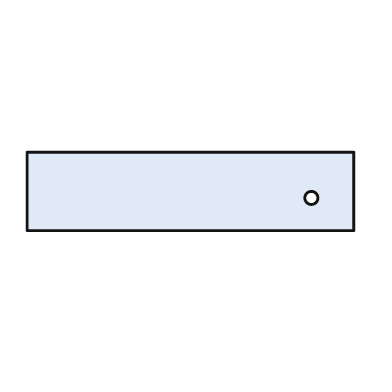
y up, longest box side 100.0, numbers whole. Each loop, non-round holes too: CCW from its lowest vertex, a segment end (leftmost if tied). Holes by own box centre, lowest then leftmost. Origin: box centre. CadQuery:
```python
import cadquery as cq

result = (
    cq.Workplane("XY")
    .moveTo(-50.0, -12.0)
    .lineTo(50.0, -12.0)
    .lineTo(50.0, 12.0)
    .lineTo(-50.0, 12.0)
    .close()
    .moveTo(37.0, -2.0)
    .circle(2.0)
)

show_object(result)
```